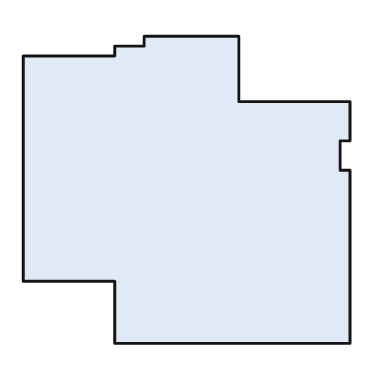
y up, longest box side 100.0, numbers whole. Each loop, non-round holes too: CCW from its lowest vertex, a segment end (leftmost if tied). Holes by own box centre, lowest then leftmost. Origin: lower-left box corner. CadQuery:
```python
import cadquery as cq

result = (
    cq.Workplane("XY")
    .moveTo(28.0, 0.0)
    .lineTo(100.0, 0.0)
    .lineTo(100.0, 53.0)
    .lineTo(97.0, 53.0)
    .lineTo(97.0, 62.0)
    .lineTo(100.0, 62.0)
    .lineTo(100.0, 74.0)
    .lineTo(66.0, 74.0)
    .lineTo(66.0, 94.0)
    .lineTo(37.0, 94.0)
    .lineTo(37.0, 91.0)
    .lineTo(28.0, 91.0)
    .lineTo(28.0, 88.0)
    .lineTo(0.0, 88.0)
    .lineTo(0.0, 19.0)
    .lineTo(28.0, 19.0)
    .close()
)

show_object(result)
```